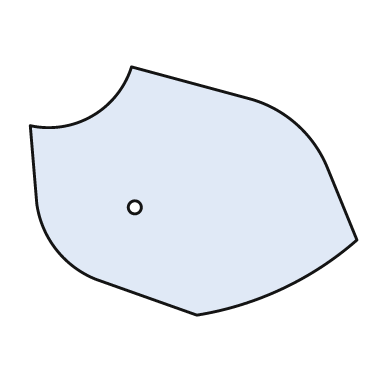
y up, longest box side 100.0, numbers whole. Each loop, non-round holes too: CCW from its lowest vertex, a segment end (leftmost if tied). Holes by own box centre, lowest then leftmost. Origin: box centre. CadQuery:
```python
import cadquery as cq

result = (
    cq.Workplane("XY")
    .moveTo(1.0, -38.0)
    .threePointArc((27.0, -30.0), (50.0, -15.0))
    .lineTo(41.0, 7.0)
    .threePointArc((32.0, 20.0), (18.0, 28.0))
    .lineTo(-19.0, 38.0)
    .threePointArc((-31.0, 23.0), (-50.0, 20.0))
    .lineTo(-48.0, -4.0)
    .threePointArc((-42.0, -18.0), (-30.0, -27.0))
    .close()
    .moveTo(-18.0, -5.0)
    .circle(2.0)
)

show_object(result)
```